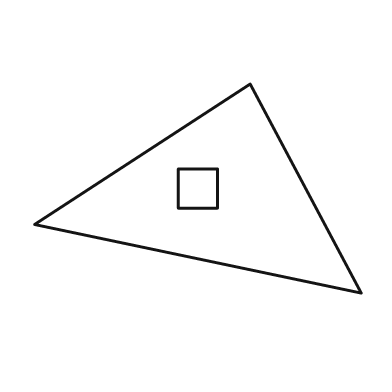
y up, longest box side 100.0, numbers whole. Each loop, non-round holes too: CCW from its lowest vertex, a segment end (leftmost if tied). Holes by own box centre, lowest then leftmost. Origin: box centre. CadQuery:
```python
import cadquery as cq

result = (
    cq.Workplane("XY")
    .moveTo(50.0, -32.0)
    .lineTo(16.0, 32.0)
    .lineTo(-50.0, -11.0)
    .close()
    .moveTo(-6.0, -6.0)
    .lineTo(6.0, -6.0)
    .lineTo(6.0, 6.0)
    .lineTo(-6.0, 6.0)
    .close()
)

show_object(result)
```